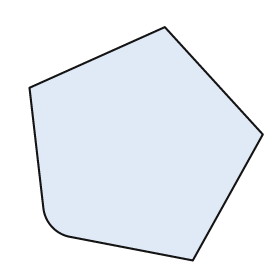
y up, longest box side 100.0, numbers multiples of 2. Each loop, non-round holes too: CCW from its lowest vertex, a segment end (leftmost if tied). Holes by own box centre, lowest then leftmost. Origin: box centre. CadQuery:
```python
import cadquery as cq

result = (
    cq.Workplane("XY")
    .moveTo(20.0, -50.0)
    .lineTo(50.0, 4.0)
    .lineTo(8.0, 50.0)
    .lineTo(-50.0, 24.0)
    .lineTo(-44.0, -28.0)
    .threePointArc((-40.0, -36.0), (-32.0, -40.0))
    .close()
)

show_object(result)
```